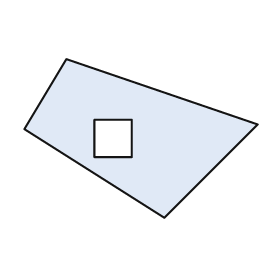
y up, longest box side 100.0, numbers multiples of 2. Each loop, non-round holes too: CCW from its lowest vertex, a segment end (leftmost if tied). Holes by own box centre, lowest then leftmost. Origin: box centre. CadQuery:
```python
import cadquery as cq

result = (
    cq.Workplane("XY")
    .moveTo(10.0, -34.0)
    .lineTo(50.0, 6.0)
    .lineTo(-32.0, 34.0)
    .lineTo(-50.0, 4.0)
    .close()
    .moveTo(-20.0, -8.0)
    .lineTo(-4.0, -8.0)
    .lineTo(-4.0, 8.0)
    .lineTo(-20.0, 8.0)
    .close()
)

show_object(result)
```